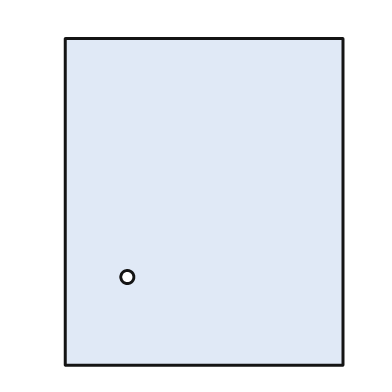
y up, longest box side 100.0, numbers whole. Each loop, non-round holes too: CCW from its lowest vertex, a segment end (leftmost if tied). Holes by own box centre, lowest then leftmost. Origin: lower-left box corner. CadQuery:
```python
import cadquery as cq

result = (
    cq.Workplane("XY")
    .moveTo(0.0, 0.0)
    .lineTo(85.0, 0.0)
    .lineTo(85.0, 100.0)
    .lineTo(0.0, 100.0)
    .close()
    .moveTo(19.0, 27.0)
    .circle(2.0)
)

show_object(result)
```